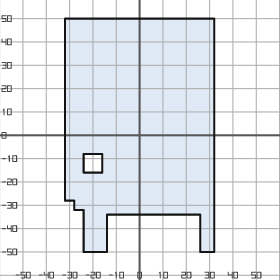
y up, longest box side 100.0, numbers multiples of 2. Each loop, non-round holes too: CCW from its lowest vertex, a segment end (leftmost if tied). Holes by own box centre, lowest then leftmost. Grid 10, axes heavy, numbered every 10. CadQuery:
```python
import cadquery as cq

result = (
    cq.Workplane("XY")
    .moveTo(-24.0, -50.0)
    .lineTo(-14.0, -50.0)
    .lineTo(-14.0, -34.0)
    .lineTo(26.0, -34.0)
    .lineTo(26.0, -50.0)
    .lineTo(32.0, -50.0)
    .lineTo(32.0, 50.0)
    .lineTo(-32.0, 50.0)
    .lineTo(-32.0, -28.0)
    .lineTo(-28.0, -28.0)
    .lineTo(-28.0, -32.0)
    .lineTo(-24.0, -32.0)
    .close()
    .moveTo(-24.0, -16.0)
    .lineTo(-16.0, -16.0)
    .lineTo(-16.0, -8.0)
    .lineTo(-24.0, -8.0)
    .close()
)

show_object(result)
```